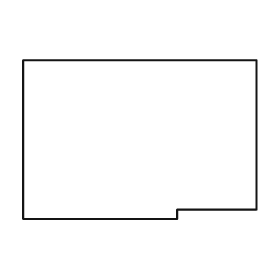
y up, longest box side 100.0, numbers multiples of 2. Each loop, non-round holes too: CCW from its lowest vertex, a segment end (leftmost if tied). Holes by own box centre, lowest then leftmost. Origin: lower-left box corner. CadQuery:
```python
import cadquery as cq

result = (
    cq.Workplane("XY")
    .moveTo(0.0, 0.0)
    .lineTo(66.0, 0.0)
    .lineTo(66.0, 4.0)
    .lineTo(100.0, 4.0)
    .lineTo(100.0, 68.0)
    .lineTo(0.0, 68.0)
    .close()
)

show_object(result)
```